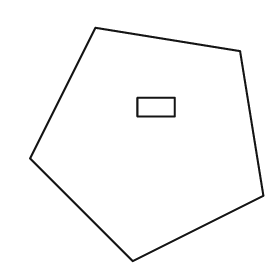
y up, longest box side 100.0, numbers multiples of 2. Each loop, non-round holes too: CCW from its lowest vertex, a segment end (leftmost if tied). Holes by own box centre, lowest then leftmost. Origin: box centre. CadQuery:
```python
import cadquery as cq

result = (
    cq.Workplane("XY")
    .moveTo(-6.0, -50.0)
    .lineTo(50.0, -22.0)
    .lineTo(40.0, 40.0)
    .lineTo(-22.0, 50.0)
    .lineTo(-50.0, -6.0)
    .close()
    .moveTo(-4.0, 12.0)
    .lineTo(12.0, 12.0)
    .lineTo(12.0, 20.0)
    .lineTo(-4.0, 20.0)
    .close()
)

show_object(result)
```